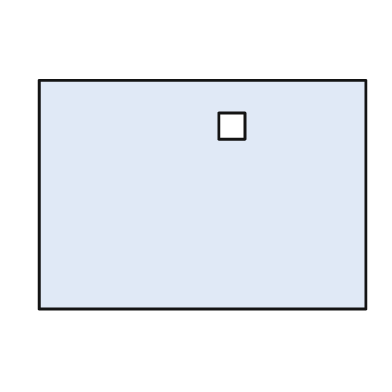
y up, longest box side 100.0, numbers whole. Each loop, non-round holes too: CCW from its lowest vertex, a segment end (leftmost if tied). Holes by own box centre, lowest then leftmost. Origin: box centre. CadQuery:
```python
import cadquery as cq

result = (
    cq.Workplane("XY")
    .moveTo(-50.0, -35.0)
    .lineTo(50.0, -35.0)
    .lineTo(50.0, 35.0)
    .lineTo(-50.0, 35.0)
    .close()
    .moveTo(5.0, 17.0)
    .lineTo(13.0, 17.0)
    .lineTo(13.0, 25.0)
    .lineTo(5.0, 25.0)
    .close()
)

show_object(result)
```